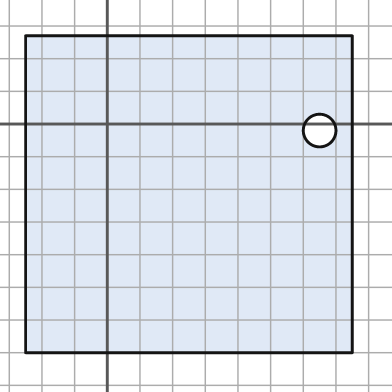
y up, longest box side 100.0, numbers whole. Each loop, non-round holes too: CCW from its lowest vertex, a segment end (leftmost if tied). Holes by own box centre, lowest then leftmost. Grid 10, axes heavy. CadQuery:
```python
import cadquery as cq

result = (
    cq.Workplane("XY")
    .moveTo(-25.0, -70.0)
    .lineTo(75.0, -70.0)
    .lineTo(75.0, 27.0)
    .lineTo(-25.0, 27.0)
    .close()
    .moveTo(65.0, -2.0)
    .circle(5.0)
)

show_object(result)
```